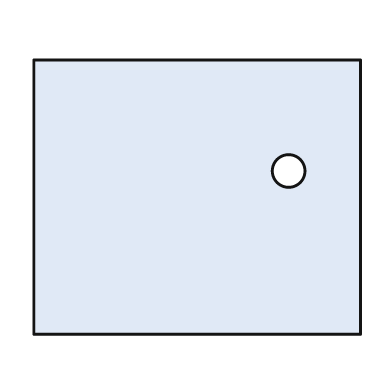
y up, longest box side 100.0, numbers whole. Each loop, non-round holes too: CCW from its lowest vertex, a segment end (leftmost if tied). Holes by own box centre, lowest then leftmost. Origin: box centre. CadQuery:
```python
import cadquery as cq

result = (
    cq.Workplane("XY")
    .moveTo(-50.0, -42.0)
    .lineTo(50.0, -42.0)
    .lineTo(50.0, 42.0)
    .lineTo(-50.0, 42.0)
    .close()
    .moveTo(28.0, 8.0)
    .circle(5.0)
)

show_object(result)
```